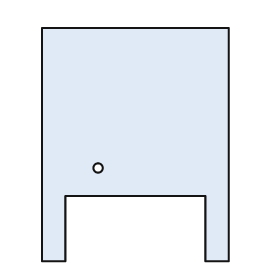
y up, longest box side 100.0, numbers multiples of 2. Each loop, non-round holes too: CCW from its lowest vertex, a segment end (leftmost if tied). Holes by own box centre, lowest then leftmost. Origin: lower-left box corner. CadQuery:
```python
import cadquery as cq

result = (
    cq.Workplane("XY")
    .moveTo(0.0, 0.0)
    .lineTo(10.0, 0.0)
    .lineTo(10.0, 28.0)
    .lineTo(70.0, 28.0)
    .lineTo(70.0, 0.0)
    .lineTo(80.0, 0.0)
    .lineTo(80.0, 100.0)
    .lineTo(0.0, 100.0)
    .close()
    .moveTo(24.0, 40.0)
    .circle(2.0)
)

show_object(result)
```